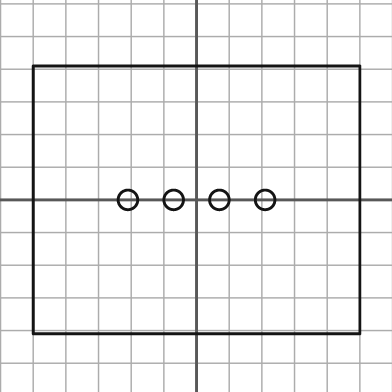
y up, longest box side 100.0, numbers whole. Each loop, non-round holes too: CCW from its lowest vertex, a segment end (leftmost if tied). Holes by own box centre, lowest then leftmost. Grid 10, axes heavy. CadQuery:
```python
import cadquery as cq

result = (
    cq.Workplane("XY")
    .moveTo(-50.0, -41.0)
    .lineTo(50.0, -41.0)
    .lineTo(50.0, 41.0)
    .lineTo(-50.0, 41.0)
    .close()
    .moveTo(-21.0, 0.0)
    .circle(3.0)
    .moveTo(-7.0, 0.0)
    .circle(3.0)
    .moveTo(7.0, 0.0)
    .circle(3.0)
    .moveTo(21.0, 0.0)
    .circle(3.0)
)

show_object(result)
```